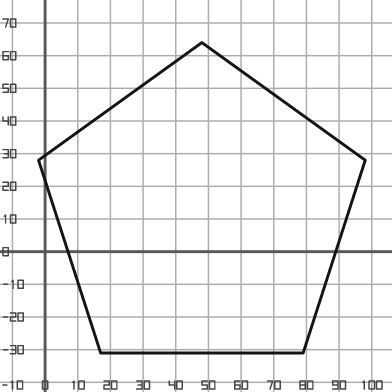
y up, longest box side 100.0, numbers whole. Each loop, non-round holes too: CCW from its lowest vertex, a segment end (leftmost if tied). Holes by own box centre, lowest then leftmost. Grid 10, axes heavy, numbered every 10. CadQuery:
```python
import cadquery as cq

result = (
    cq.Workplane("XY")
    .moveTo(17.0, -31.0)
    .lineTo(79.0, -31.0)
    .lineTo(98.0, 28.0)
    .lineTo(48.0, 64.0)
    .lineTo(-2.0, 28.0)
    .close()
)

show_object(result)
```